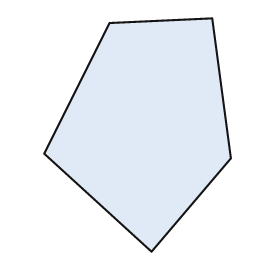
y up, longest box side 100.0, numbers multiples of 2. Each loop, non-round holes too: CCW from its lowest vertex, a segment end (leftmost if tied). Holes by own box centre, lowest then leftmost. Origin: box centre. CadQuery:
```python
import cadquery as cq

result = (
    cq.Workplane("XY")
    .moveTo(6.0, -50.0)
    .lineTo(40.0, -10.0)
    .lineTo(32.0, 50.0)
    .lineTo(-12.0, 48.0)
    .lineTo(-40.0, -8.0)
    .close()
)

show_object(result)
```